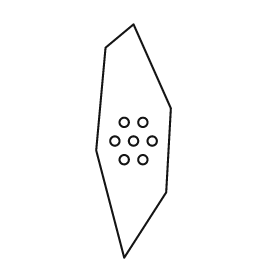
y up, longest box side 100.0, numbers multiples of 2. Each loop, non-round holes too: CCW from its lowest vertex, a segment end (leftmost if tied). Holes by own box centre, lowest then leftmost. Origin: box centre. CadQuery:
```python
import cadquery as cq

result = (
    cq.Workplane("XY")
    .moveTo(-4.0, -50.0)
    .lineTo(14.0, -22.0)
    .lineTo(16.0, 14.0)
    .lineTo(0.0, 50.0)
    .lineTo(-12.0, 40.0)
    .lineTo(-16.0, -4.0)
    .close()
    .moveTo(-4.0, -8.0)
    .circle(2.0)
    .moveTo(4.0, -8.0)
    .circle(2.0)
    .moveTo(-8.0, 0.0)
    .circle(2.0)
    .moveTo(0.0, 0.0)
    .circle(2.0)
    .moveTo(8.0, 0.0)
    .circle(2.0)
    .moveTo(-4.0, 8.0)
    .circle(2.0)
    .moveTo(4.0, 8.0)
    .circle(2.0)
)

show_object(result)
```